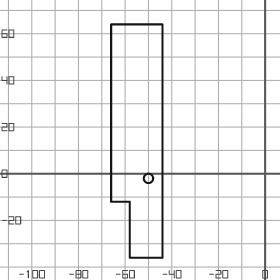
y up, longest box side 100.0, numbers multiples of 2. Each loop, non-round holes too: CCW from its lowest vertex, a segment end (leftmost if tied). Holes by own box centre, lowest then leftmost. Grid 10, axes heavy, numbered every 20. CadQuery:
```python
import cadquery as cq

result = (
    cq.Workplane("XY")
    .moveTo(-58.0, -36.0)
    .lineTo(-44.0, -36.0)
    .lineTo(-44.0, 64.0)
    .lineTo(-66.0, 64.0)
    .lineTo(-66.0, -12.0)
    .lineTo(-58.0, -12.0)
    .close()
    .moveTo(-50.0, -2.0)
    .circle(2.0)
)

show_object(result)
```